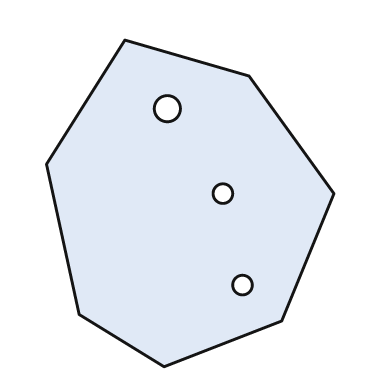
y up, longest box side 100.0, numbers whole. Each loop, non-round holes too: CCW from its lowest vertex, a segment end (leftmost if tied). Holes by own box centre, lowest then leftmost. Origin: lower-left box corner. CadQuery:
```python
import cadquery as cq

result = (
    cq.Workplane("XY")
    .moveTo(36.0, 0.0)
    .lineTo(72.0, 14.0)
    .lineTo(88.0, 53.0)
    .lineTo(62.0, 89.0)
    .lineTo(24.0, 100.0)
    .lineTo(0.0, 62.0)
    .lineTo(10.0, 16.0)
    .close()
    .moveTo(60.0, 25.0)
    .circle(3.0)
    .moveTo(54.0, 53.0)
    .circle(3.0)
    .moveTo(37.0, 79.0)
    .circle(4.0)
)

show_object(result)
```